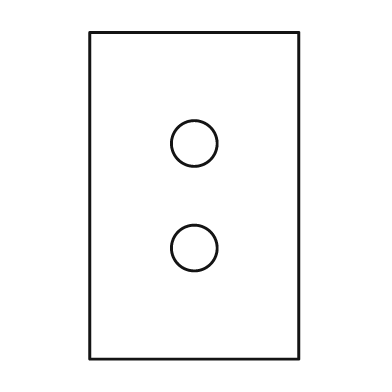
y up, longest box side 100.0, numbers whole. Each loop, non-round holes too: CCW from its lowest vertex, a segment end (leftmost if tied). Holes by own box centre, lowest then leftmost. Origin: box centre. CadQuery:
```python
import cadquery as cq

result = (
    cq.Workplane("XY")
    .moveTo(-32.0, -50.0)
    .lineTo(32.0, -50.0)
    .lineTo(32.0, 50.0)
    .lineTo(-32.0, 50.0)
    .close()
    .moveTo(0.0, -16.0)
    .circle(7.0)
    .moveTo(0.0, 16.0)
    .circle(7.0)
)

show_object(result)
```